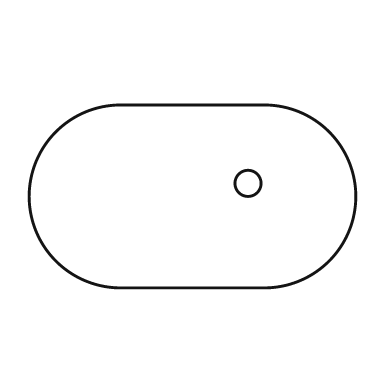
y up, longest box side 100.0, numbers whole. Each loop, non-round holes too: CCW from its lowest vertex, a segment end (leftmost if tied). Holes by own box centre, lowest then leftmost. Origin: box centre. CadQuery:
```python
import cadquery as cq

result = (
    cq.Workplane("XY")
    .moveTo(-22.0, -28.0)
    .lineTo(22.0, -28.0)
    .threePointArc((50.0, 0.0), (22.0, 28.0))
    .lineTo(-22.0, 28.0)
    .threePointArc((-50.0, 0.0), (-22.0, -28.0))
    .close()
    .moveTo(17.0, 4.0)
    .circle(4.0)
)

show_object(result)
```